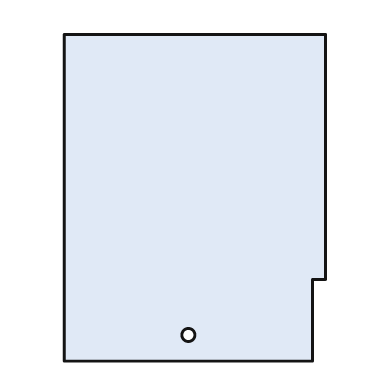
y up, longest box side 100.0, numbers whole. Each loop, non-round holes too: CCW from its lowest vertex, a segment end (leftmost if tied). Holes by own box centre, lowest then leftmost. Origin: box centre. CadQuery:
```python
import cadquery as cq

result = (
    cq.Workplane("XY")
    .moveTo(-40.0, -50.0)
    .lineTo(36.0, -50.0)
    .lineTo(36.0, -25.0)
    .lineTo(40.0, -25.0)
    .lineTo(40.0, 50.0)
    .lineTo(-40.0, 50.0)
    .close()
    .moveTo(-2.0, -42.0)
    .circle(2.0)
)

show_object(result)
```